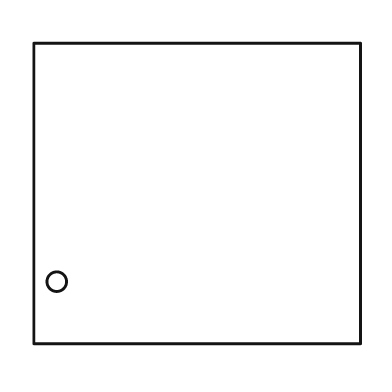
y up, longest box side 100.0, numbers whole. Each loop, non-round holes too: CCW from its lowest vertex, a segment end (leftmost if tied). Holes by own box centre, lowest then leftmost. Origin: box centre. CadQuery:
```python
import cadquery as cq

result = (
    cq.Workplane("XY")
    .moveTo(-50.0, -46.0)
    .lineTo(50.0, -46.0)
    .lineTo(50.0, 46.0)
    .lineTo(-50.0, 46.0)
    .close()
    .moveTo(-43.0, -27.0)
    .circle(3.0)
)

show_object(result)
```